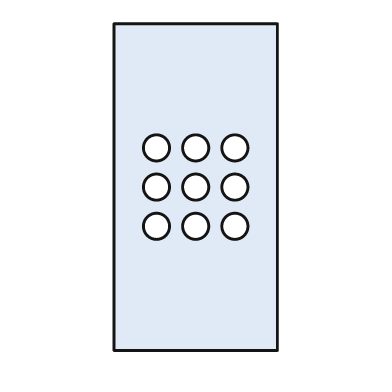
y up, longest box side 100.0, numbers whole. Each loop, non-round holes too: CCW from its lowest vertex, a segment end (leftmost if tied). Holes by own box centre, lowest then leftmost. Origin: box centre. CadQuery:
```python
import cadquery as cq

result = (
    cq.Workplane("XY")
    .moveTo(-25.0, -50.0)
    .lineTo(25.0, -50.0)
    .lineTo(25.0, 50.0)
    .lineTo(-25.0, 50.0)
    .close()
    .moveTo(-12.0, -12.0)
    .circle(4.0)
    .moveTo(0.0, -12.0)
    .circle(4.0)
    .moveTo(12.0, -12.0)
    .circle(4.0)
    .moveTo(-12.0, 0.0)
    .circle(4.0)
    .moveTo(0.0, 0.0)
    .circle(4.0)
    .moveTo(12.0, 0.0)
    .circle(4.0)
    .moveTo(-12.0, 12.0)
    .circle(4.0)
    .moveTo(0.0, 12.0)
    .circle(4.0)
    .moveTo(12.0, 12.0)
    .circle(4.0)
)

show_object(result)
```